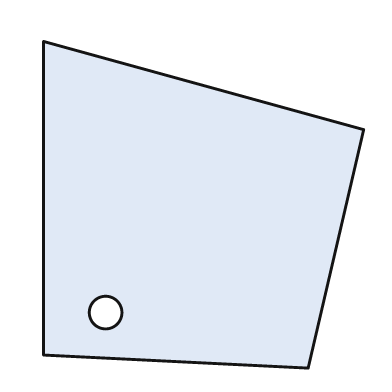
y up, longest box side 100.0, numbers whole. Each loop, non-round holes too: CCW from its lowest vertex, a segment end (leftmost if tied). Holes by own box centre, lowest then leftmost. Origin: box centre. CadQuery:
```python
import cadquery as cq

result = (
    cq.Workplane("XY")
    .moveTo(32.0, -50.0)
    .lineTo(49.0, 23.0)
    .lineTo(-49.0, 50.0)
    .lineTo(-49.0, -46.0)
    .close()
    .moveTo(-30.0, -33.0)
    .circle(5.0)
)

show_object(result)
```